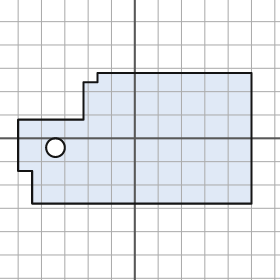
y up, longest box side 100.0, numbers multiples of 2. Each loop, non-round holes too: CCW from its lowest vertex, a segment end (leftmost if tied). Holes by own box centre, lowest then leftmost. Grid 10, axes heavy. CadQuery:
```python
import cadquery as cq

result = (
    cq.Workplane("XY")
    .moveTo(-44.0, -28.0)
    .lineTo(50.0, -28.0)
    .lineTo(50.0, 28.0)
    .lineTo(-16.0, 28.0)
    .lineTo(-16.0, 24.0)
    .lineTo(-22.0, 24.0)
    .lineTo(-22.0, 8.0)
    .lineTo(-50.0, 8.0)
    .lineTo(-50.0, -14.0)
    .lineTo(-44.0, -14.0)
    .close()
    .moveTo(-34.0, -4.0)
    .circle(4.0)
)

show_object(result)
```